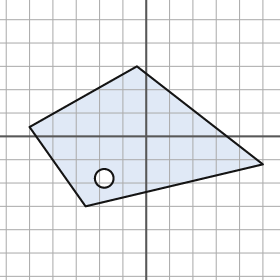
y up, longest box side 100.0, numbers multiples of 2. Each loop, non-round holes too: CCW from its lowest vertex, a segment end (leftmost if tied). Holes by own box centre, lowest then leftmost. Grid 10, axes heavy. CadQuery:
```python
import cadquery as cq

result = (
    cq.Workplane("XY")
    .moveTo(-26.0, -30.0)
    .lineTo(50.0, -12.0)
    .lineTo(-4.0, 30.0)
    .lineTo(-50.0, 4.0)
    .close()
    .moveTo(-18.0, -18.0)
    .circle(4.0)
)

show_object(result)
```